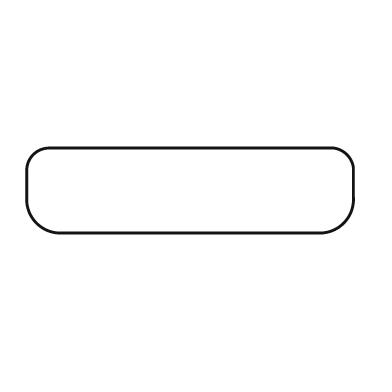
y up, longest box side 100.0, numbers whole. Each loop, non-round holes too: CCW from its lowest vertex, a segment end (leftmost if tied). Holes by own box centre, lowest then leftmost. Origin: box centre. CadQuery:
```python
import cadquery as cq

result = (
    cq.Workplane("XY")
    .moveTo(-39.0, -13.0)
    .lineTo(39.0, -13.0)
    .threePointArc((47.0, -10.0), (50.0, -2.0))
    .lineTo(50.0, 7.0)
    .threePointArc((48.0, 11.0), (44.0, 13.0))
    .lineTo(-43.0, 13.0)
    .threePointArc((-48.0, 11.0), (-50.0, 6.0))
    .lineTo(-50.0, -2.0)
    .threePointArc((-47.0, -10.0), (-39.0, -13.0))
    .close()
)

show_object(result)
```